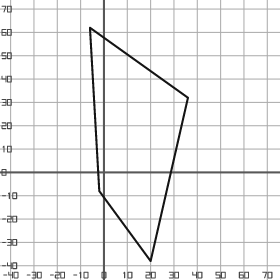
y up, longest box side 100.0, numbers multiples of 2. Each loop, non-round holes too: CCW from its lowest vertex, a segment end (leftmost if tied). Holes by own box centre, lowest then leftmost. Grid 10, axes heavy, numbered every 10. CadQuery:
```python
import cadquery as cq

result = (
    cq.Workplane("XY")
    .moveTo(20.0, -38.0)
    .lineTo(36.0, 32.0)
    .lineTo(-6.0, 62.0)
    .lineTo(-2.0, -8.0)
    .close()
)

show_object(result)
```